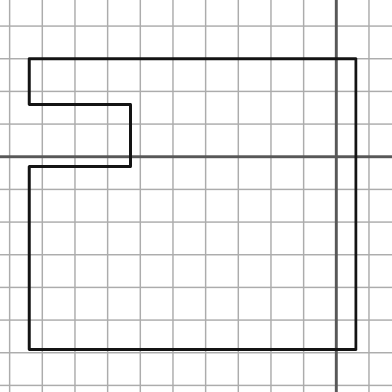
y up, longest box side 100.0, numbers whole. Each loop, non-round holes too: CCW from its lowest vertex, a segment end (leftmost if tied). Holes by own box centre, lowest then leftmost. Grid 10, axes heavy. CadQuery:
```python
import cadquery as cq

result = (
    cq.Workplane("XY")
    .moveTo(-94.0, -59.0)
    .lineTo(6.0, -59.0)
    .lineTo(6.0, 30.0)
    .lineTo(-94.0, 30.0)
    .lineTo(-94.0, 16.0)
    .lineTo(-63.0, 16.0)
    .lineTo(-63.0, -3.0)
    .lineTo(-94.0, -3.0)
    .close()
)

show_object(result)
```